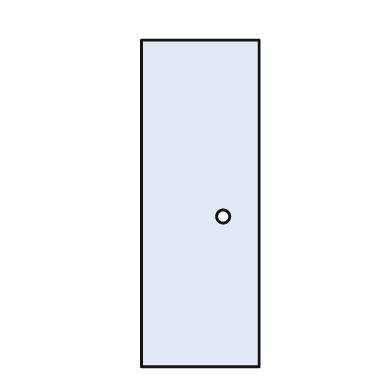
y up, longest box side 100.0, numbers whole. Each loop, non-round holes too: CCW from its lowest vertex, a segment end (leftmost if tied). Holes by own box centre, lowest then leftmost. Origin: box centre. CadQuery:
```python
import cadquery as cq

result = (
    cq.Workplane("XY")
    .moveTo(-18.0, -50.0)
    .lineTo(18.0, -50.0)
    .lineTo(18.0, 50.0)
    .lineTo(-18.0, 50.0)
    .close()
    .moveTo(7.0, -4.0)
    .circle(2.0)
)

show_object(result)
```